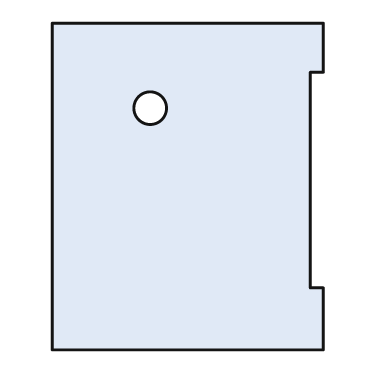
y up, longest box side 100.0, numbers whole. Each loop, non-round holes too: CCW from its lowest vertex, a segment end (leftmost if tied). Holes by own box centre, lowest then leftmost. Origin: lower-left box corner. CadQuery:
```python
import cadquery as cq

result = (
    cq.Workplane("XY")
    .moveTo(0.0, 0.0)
    .lineTo(83.0, 0.0)
    .lineTo(83.0, 19.0)
    .lineTo(79.0, 19.0)
    .lineTo(79.0, 85.0)
    .lineTo(83.0, 85.0)
    .lineTo(83.0, 100.0)
    .lineTo(0.0, 100.0)
    .close()
    .moveTo(30.0, 74.0)
    .circle(5.0)
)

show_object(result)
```